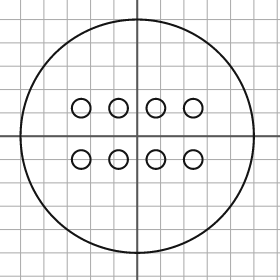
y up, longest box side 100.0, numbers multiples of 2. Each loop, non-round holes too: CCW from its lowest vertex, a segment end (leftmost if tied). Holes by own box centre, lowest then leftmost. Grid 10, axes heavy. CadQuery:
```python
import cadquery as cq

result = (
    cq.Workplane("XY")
    .moveTo(0.0, 0.0)
    .circle(50.0)
    .moveTo(-24.0, -10.0)
    .circle(4.0)
    .moveTo(-8.0, -10.0)
    .circle(4.0)
    .moveTo(8.0, -10.0)
    .circle(4.0)
    .moveTo(24.0, -10.0)
    .circle(4.0)
    .moveTo(-24.0, 12.0)
    .circle(4.0)
    .moveTo(-8.0, 12.0)
    .circle(4.0)
    .moveTo(8.0, 12.0)
    .circle(4.0)
    .moveTo(24.0, 12.0)
    .circle(4.0)
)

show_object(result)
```